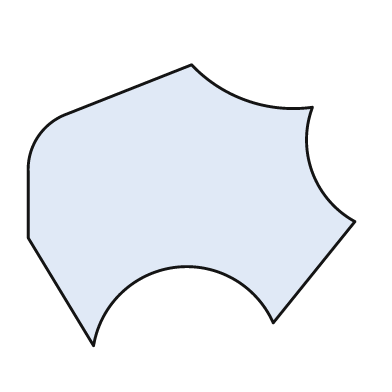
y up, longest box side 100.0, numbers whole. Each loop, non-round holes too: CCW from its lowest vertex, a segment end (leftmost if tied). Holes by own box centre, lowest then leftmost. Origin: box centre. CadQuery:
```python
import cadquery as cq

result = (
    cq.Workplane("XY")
    .moveTo(-30.0, -43.0)
    .threePointArc((-5.0, -19.0), (25.0, -36.0))
    .lineTo(50.0, -5.0)
    .threePointArc((37.0, 10.0), (37.0, 30.0))
    .threePointArc((17.0, 32.0), (0.0, 43.0))
    .lineTo(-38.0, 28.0)
    .threePointArc((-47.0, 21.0), (-50.0, 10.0))
    .lineTo(-50.0, -10.0)
    .close()
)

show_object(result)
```